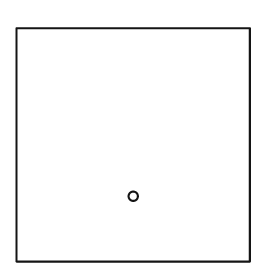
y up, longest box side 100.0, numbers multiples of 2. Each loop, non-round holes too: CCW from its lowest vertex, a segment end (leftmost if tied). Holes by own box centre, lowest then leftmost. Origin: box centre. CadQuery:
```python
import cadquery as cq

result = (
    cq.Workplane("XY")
    .moveTo(-50.0, -50.0)
    .lineTo(50.0, -50.0)
    .lineTo(50.0, 50.0)
    .lineTo(-50.0, 50.0)
    .close()
    .moveTo(0.0, -22.0)
    .circle(2.0)
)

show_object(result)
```